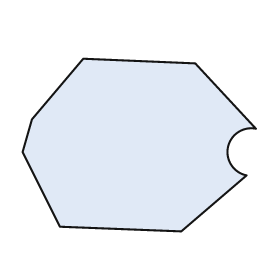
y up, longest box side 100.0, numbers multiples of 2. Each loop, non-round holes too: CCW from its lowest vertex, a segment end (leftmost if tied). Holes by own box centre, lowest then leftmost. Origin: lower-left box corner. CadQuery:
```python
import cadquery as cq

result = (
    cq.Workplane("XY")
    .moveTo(68.0, 0.0)
    .lineTo(96.0, 24.0)
    .threePointArc((88.0, 36.0), (100.0, 44.0))
    .lineTo(74.0, 72.0)
    .lineTo(26.0, 74.0)
    .lineTo(4.0, 48.0)
    .lineTo(0.0, 34.0)
    .lineTo(16.0, 2.0)
    .close()
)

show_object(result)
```